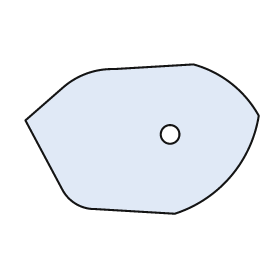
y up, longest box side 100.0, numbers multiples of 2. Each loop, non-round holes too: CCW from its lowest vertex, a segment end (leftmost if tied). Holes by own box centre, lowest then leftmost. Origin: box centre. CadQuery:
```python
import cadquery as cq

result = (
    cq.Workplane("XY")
    .moveTo(14.0, -32.0)
    .threePointArc((38.0, -16.0), (50.0, 10.0))
    .threePointArc((38.0, 24.0), (22.0, 32.0))
    .lineTo(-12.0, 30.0)
    .threePointArc((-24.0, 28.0), (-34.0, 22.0))
    .lineTo(-50.0, 8.0)
    .lineTo(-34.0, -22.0)
    .threePointArc((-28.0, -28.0), (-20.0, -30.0))
    .close()
    .moveTo(12.0, 2.0)
    .circle(4.0)
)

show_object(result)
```